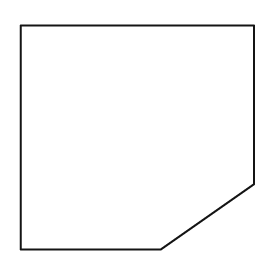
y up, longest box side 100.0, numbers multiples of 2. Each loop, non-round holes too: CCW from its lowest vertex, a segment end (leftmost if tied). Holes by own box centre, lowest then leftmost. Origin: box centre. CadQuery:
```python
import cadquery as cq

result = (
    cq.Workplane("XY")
    .moveTo(-50.0, -48.0)
    .lineTo(10.0, -48.0)
    .lineTo(50.0, -20.0)
    .lineTo(50.0, 48.0)
    .lineTo(-50.0, 48.0)
    .close()
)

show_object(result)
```